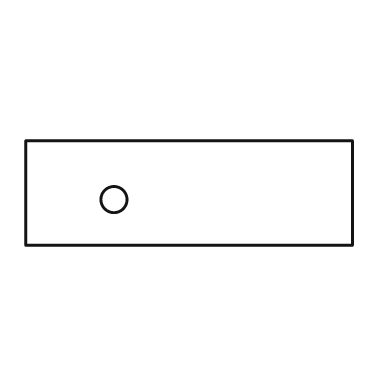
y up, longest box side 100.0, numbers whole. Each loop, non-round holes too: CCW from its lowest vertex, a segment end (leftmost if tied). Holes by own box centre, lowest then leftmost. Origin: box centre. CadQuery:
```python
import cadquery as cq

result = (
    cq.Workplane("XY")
    .moveTo(-50.0, -16.0)
    .lineTo(50.0, -16.0)
    .lineTo(50.0, 16.0)
    .lineTo(-50.0, 16.0)
    .close()
    .moveTo(-23.0, -2.0)
    .circle(4.0)
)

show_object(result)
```